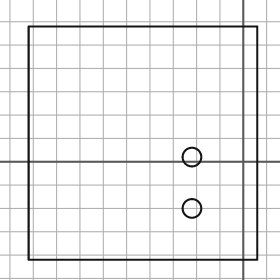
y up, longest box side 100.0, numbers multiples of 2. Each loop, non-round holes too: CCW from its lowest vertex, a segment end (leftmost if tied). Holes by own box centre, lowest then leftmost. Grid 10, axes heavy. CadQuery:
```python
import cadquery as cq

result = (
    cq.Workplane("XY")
    .moveTo(-92.0, -42.0)
    .lineTo(6.0, -42.0)
    .lineTo(6.0, 58.0)
    .lineTo(-92.0, 58.0)
    .close()
    .moveTo(-22.0, -20.0)
    .circle(4.0)
    .moveTo(-22.0, 2.0)
    .circle(4.0)
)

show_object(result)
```